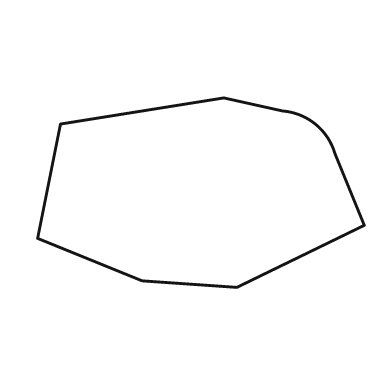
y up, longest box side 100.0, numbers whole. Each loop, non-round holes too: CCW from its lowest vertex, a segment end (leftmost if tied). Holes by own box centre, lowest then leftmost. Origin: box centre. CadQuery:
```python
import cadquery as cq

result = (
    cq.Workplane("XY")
    .moveTo(11.0, -29.0)
    .lineTo(50.0, -10.0)
    .lineTo(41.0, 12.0)
    .threePointArc((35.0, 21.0), (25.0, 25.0))
    .lineTo(7.0, 29.0)
    .lineTo(-43.0, 21.0)
    .lineTo(-50.0, -14.0)
    .lineTo(-18.0, -27.0)
    .close()
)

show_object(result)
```